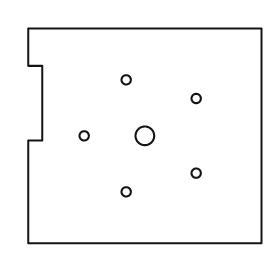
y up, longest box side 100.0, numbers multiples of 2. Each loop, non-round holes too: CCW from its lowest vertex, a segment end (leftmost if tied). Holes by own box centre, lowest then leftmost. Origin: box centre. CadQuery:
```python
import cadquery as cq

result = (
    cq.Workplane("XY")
    .moveTo(-50.0, -46.0)
    .lineTo(50.0, -46.0)
    .lineTo(50.0, 46.0)
    .lineTo(-50.0, 46.0)
    .lineTo(-50.0, 30.0)
    .lineTo(-44.0, 30.0)
    .lineTo(-44.0, -2.0)
    .lineTo(-50.0, -2.0)
    .close()
    .moveTo(-8.0, -24.0)
    .circle(2.0)
    .moveTo(22.0, -16.0)
    .circle(2.0)
    .moveTo(-26.0, 0.0)
    .circle(2.0)
    .moveTo(0.0, 0.0)
    .circle(4.0)
    .moveTo(22.0, 16.0)
    .circle(2.0)
    .moveTo(-8.0, 24.0)
    .circle(2.0)
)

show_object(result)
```